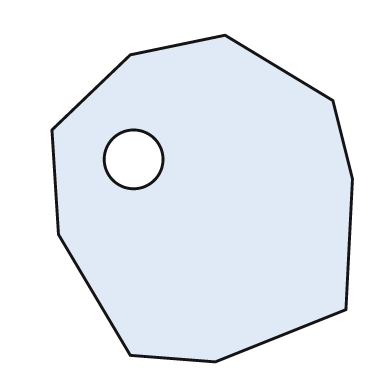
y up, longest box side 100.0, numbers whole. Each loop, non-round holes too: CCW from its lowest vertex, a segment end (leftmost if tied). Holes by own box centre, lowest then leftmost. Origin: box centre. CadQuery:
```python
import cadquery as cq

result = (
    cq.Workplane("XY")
    .moveTo(4.0, -50.0)
    .lineTo(44.0, -34.0)
    .lineTo(46.0, 6.0)
    .lineTo(40.0, 30.0)
    .lineTo(7.0, 50.0)
    .lineTo(-22.0, 44.0)
    .lineTo(-46.0, 21.0)
    .lineTo(-44.0, -11.0)
    .lineTo(-22.0, -48.0)
    .close()
    .moveTo(-21.0, 12.0)
    .circle(9.0)
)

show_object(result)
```